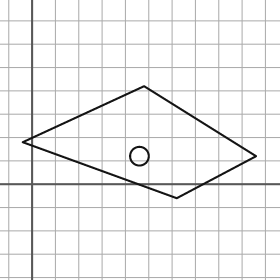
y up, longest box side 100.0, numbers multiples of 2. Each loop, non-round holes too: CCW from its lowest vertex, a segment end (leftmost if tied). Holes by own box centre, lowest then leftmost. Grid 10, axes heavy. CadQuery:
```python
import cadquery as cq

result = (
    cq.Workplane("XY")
    .moveTo(62.0, -6.0)
    .lineTo(96.0, 12.0)
    .lineTo(48.0, 42.0)
    .lineTo(-4.0, 18.0)
    .close()
    .moveTo(46.0, 12.0)
    .circle(4.0)
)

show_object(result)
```